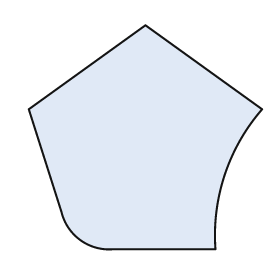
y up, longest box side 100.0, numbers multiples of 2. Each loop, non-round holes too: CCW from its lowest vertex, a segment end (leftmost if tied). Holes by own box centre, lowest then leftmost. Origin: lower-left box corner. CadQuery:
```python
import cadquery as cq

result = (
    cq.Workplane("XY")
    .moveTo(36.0, 0.0)
    .lineTo(80.0, 0.0)
    .threePointArc((84.0, 32.0), (100.0, 60.0))
    .lineTo(50.0, 96.0)
    .lineTo(0.0, 60.0)
    .lineTo(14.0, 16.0)
    .threePointArc((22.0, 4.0), (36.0, 0.0))
    .close()
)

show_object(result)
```